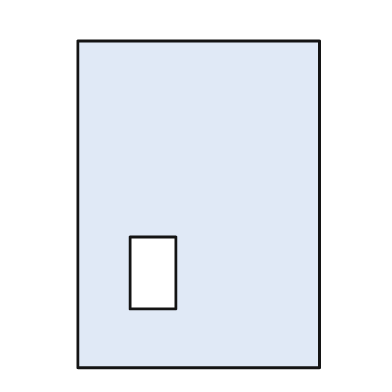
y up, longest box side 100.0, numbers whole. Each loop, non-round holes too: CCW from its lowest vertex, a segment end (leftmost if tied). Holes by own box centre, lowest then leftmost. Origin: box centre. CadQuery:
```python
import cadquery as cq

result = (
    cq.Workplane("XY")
    .moveTo(-37.0, -50.0)
    .lineTo(37.0, -50.0)
    .lineTo(37.0, 50.0)
    .lineTo(-37.0, 50.0)
    .close()
    .moveTo(-21.0, -32.0)
    .lineTo(-7.0, -32.0)
    .lineTo(-7.0, -10.0)
    .lineTo(-21.0, -10.0)
    .close()
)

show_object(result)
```